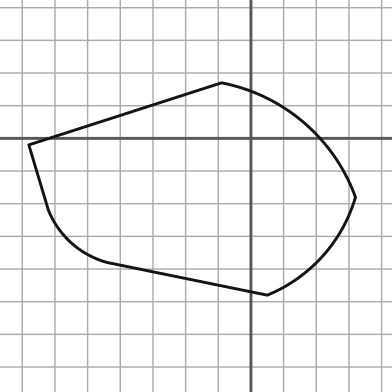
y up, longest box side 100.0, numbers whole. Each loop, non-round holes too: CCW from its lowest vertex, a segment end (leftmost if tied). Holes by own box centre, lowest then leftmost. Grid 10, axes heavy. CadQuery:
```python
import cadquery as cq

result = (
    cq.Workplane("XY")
    .moveTo(5.0, -48.0)
    .threePointArc((22.0, -36.0), (32.0, -18.0))
    .threePointArc((16.0, 5.0), (-9.0, 17.0))
    .lineTo(-68.0, -2.0)
    .lineTo(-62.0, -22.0)
    .threePointArc((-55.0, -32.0), (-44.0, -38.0))
    .close()
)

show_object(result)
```